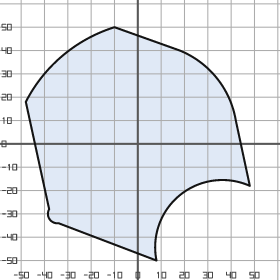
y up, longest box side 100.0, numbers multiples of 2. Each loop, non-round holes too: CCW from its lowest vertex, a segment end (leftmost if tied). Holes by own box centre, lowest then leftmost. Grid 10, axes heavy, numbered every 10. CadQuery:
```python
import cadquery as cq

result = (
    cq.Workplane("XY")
    .moveTo(8.0, -50.0)
    .threePointArc((18.0, -22.0), (48.0, -18.0))
    .lineTo(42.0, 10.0)
    .threePointArc((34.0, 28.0), (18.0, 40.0))
    .lineTo(-10.0, 50.0)
    .threePointArc((-32.0, 38.0), (-48.0, 18.0))
    .lineTo(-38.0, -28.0)
    .threePointArc((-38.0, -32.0), (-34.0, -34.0))
    .close()
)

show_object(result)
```